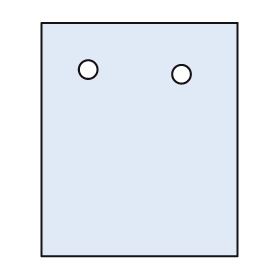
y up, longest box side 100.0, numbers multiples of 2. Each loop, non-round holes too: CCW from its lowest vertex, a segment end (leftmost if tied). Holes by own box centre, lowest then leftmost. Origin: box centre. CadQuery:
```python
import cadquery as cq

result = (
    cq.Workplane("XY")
    .moveTo(-42.0, -50.0)
    .lineTo(42.0, -50.0)
    .lineTo(42.0, 50.0)
    .lineTo(-42.0, 50.0)
    .close()
    .moveTo(18.0, 28.0)
    .circle(4.0)
    .moveTo(-22.0, 30.0)
    .circle(4.0)
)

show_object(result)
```